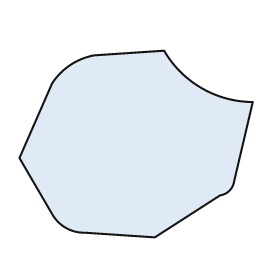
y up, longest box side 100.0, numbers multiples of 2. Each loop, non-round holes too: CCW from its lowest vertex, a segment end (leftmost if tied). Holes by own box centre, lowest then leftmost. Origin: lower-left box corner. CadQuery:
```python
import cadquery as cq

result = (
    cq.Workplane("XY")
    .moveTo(58.0, 0.0)
    .lineTo(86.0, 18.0)
    .threePointArc((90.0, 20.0), (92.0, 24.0))
    .lineTo(100.0, 58.0)
    .threePointArc((78.0, 64.0), (62.0, 80.0))
    .lineTo(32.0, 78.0)
    .threePointArc((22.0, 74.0), (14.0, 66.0))
    .lineTo(0.0, 34.0)
    .lineTo(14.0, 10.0)
    .threePointArc((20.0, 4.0), (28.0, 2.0))
    .close()
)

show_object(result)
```